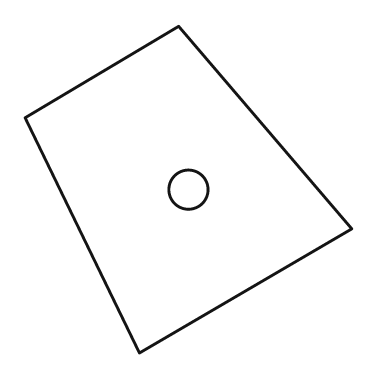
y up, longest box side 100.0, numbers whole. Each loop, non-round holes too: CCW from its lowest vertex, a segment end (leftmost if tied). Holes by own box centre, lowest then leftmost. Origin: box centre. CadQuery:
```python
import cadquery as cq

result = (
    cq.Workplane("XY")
    .moveTo(-15.0, -50.0)
    .lineTo(50.0, -12.0)
    .lineTo(-3.0, 50.0)
    .lineTo(-50.0, 22.0)
    .close()
    .moveTo(0.0, 0.0)
    .circle(6.0)
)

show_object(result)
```